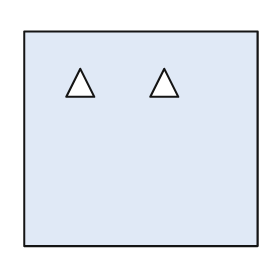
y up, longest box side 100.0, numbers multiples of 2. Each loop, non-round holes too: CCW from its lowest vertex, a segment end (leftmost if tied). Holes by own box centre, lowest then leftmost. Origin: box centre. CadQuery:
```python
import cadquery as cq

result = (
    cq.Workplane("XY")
    .moveTo(-50.0, -46.0)
    .lineTo(50.0, -46.0)
    .lineTo(50.0, 46.0)
    .lineTo(-50.0, 46.0)
    .close()
    .moveTo(-32.0, 18.0)
    .lineTo(-20.0, 18.0)
    .lineTo(-26.0, 30.0)
    .close()
    .moveTo(4.0, 18.0)
    .lineTo(16.0, 18.0)
    .lineTo(10.0, 30.0)
    .close()
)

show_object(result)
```